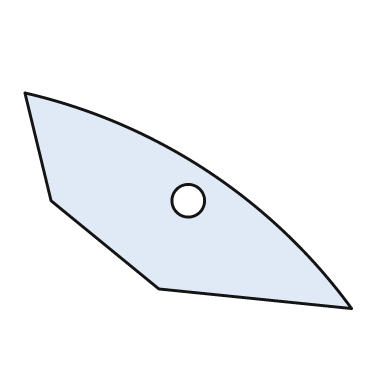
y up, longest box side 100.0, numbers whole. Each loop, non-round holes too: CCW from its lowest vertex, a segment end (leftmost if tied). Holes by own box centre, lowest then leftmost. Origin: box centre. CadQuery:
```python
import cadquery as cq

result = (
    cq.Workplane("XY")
    .moveTo(50.0, -33.0)
    .threePointArc((6.0, 9.0), (-50.0, 33.0))
    .lineTo(-42.0, 0.0)
    .lineTo(-9.0, -27.0)
    .close()
    .moveTo(0.0, 0.0)
    .circle(5.0)
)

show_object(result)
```